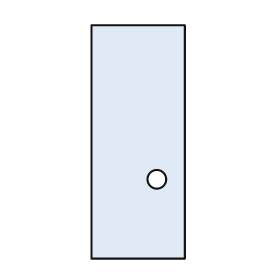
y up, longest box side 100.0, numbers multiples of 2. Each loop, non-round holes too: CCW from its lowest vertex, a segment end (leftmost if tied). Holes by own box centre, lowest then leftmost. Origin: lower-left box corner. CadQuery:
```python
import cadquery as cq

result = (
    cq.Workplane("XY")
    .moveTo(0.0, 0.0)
    .lineTo(40.0, 0.0)
    .lineTo(40.0, 100.0)
    .lineTo(0.0, 100.0)
    .close()
    .moveTo(28.0, 34.0)
    .circle(4.0)
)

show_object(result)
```